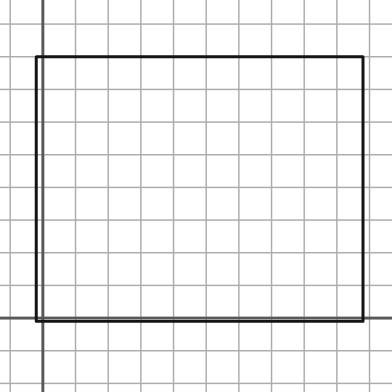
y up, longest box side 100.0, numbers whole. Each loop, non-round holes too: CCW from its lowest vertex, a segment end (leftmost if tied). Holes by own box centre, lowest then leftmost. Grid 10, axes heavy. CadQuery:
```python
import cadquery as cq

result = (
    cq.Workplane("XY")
    .moveTo(-2.0, -1.0)
    .lineTo(98.0, -1.0)
    .lineTo(98.0, 80.0)
    .lineTo(-2.0, 80.0)
    .close()
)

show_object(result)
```